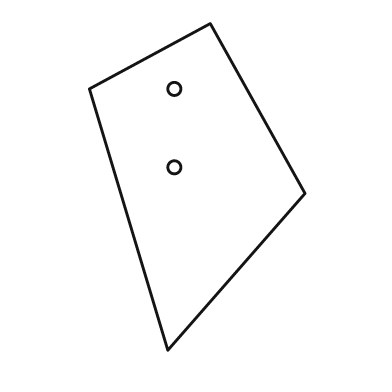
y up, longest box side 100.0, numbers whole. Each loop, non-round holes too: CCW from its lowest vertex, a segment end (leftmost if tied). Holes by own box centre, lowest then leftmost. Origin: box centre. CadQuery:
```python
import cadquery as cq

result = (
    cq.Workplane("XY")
    .moveTo(-9.0, -50.0)
    .lineTo(33.0, -2.0)
    .lineTo(4.0, 50.0)
    .lineTo(-33.0, 30.0)
    .close()
    .moveTo(-7.0, 6.0)
    .circle(2.0)
    .moveTo(-7.0, 30.0)
    .circle(2.0)
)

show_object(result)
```